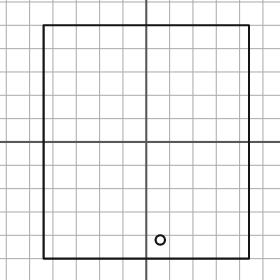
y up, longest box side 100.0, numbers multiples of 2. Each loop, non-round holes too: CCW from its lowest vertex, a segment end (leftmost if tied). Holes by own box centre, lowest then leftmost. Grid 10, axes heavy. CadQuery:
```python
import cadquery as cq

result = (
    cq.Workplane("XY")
    .moveTo(-44.0, -50.0)
    .lineTo(44.0, -50.0)
    .lineTo(44.0, 50.0)
    .lineTo(-44.0, 50.0)
    .close()
    .moveTo(6.0, -42.0)
    .circle(2.0)
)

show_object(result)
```